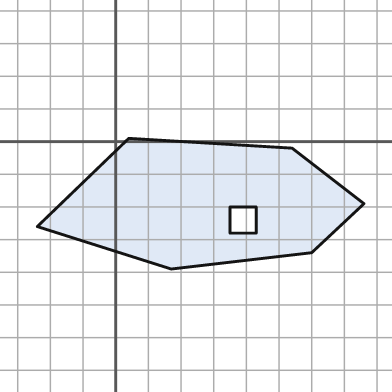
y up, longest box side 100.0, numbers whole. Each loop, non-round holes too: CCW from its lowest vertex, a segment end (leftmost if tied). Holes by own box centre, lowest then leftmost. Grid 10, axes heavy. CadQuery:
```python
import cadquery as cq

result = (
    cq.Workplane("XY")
    .moveTo(17.0, -39.0)
    .lineTo(60.0, -34.0)
    .lineTo(76.0, -19.0)
    .lineTo(54.0, -2.0)
    .lineTo(4.0, 1.0)
    .lineTo(-24.0, -26.0)
    .close()
    .moveTo(35.0, -28.0)
    .lineTo(43.0, -28.0)
    .lineTo(43.0, -20.0)
    .lineTo(35.0, -20.0)
    .close()
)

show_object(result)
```